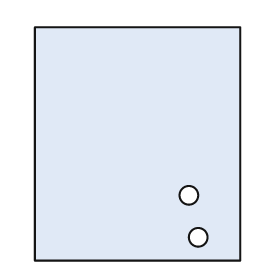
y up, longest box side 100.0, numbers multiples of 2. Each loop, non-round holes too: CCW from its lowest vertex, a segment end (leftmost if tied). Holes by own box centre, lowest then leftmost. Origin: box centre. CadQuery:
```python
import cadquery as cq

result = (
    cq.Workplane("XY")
    .moveTo(-44.0, -50.0)
    .lineTo(44.0, -50.0)
    .lineTo(44.0, 50.0)
    .lineTo(-44.0, 50.0)
    .close()
    .moveTo(26.0, -40.0)
    .circle(4.0)
    .moveTo(22.0, -22.0)
    .circle(4.0)
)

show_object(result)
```